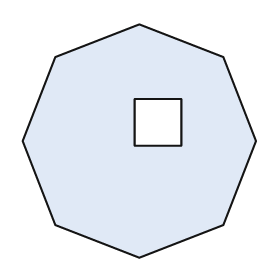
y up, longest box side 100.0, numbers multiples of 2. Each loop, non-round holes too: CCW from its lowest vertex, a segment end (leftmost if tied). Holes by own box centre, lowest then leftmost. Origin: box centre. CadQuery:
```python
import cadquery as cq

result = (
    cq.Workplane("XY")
    .moveTo(0.0, -50.0)
    .lineTo(36.0, -36.0)
    .lineTo(50.0, 0.0)
    .lineTo(36.0, 36.0)
    .lineTo(0.0, 50.0)
    .lineTo(-36.0, 36.0)
    .lineTo(-50.0, 0.0)
    .lineTo(-36.0, -36.0)
    .close()
    .moveTo(-2.0, -2.0)
    .lineTo(18.0, -2.0)
    .lineTo(18.0, 18.0)
    .lineTo(-2.0, 18.0)
    .close()
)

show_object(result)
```